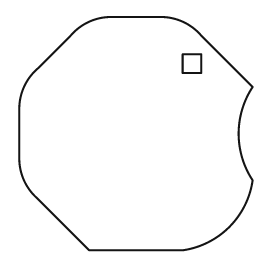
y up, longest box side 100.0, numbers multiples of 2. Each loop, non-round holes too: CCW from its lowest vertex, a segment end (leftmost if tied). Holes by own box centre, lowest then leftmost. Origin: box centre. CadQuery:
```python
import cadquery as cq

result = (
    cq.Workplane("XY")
    .moveTo(-20.0, -50.0)
    .lineTo(20.0, -50.0)
    .threePointArc((40.0, -40.0), (50.0, -20.0))
    .threePointArc((44.0, 0.0), (50.0, 20.0))
    .lineTo(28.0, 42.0)
    .threePointArc((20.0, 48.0), (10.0, 50.0))
    .lineTo(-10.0, 50.0)
    .threePointArc((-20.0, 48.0), (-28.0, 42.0))
    .lineTo(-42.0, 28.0)
    .threePointArc((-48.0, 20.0), (-50.0, 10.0))
    .lineTo(-50.0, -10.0)
    .threePointArc((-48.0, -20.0), (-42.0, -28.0))
    .close()
    .moveTo(20.0, 26.0)
    .lineTo(28.0, 26.0)
    .lineTo(28.0, 34.0)
    .lineTo(20.0, 34.0)
    .close()
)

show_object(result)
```